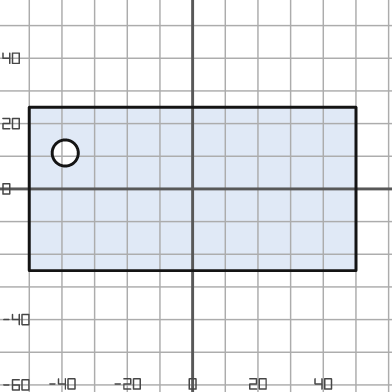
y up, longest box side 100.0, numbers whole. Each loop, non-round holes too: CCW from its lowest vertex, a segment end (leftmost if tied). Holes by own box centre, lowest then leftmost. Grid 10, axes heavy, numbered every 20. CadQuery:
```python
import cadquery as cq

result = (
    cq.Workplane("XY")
    .moveTo(-50.0, -25.0)
    .lineTo(50.0, -25.0)
    .lineTo(50.0, 25.0)
    .lineTo(-50.0, 25.0)
    .close()
    .moveTo(-39.0, 11.0)
    .circle(4.0)
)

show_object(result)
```